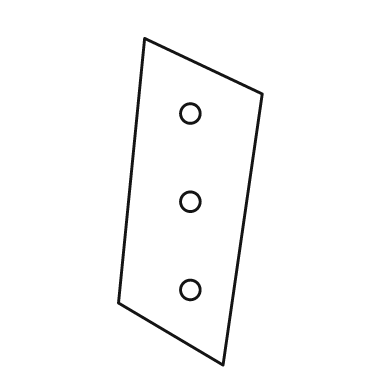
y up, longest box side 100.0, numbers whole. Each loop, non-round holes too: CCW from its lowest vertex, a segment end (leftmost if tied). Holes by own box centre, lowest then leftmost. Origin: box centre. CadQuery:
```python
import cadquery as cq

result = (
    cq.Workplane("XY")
    .moveTo(10.0, -50.0)
    .lineTo(22.0, 33.0)
    .lineTo(-14.0, 50.0)
    .lineTo(-22.0, -31.0)
    .close()
    .moveTo(0.0, -27.0)
    .circle(3.0)
    .moveTo(0.0, 0.0)
    .circle(3.0)
    .moveTo(0.0, 27.0)
    .circle(3.0)
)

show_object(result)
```